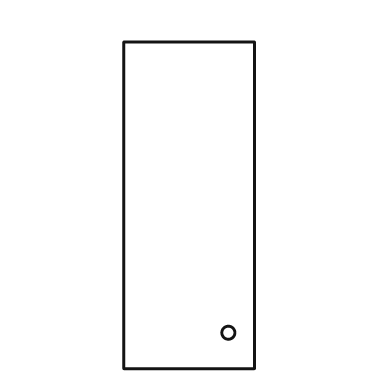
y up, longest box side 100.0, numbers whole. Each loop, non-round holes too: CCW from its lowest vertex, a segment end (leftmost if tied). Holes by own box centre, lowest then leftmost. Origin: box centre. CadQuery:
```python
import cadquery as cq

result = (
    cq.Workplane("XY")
    .moveTo(-20.0, -50.0)
    .lineTo(20.0, -50.0)
    .lineTo(20.0, 50.0)
    .lineTo(-20.0, 50.0)
    .close()
    .moveTo(12.0, -39.0)
    .circle(2.0)
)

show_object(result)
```